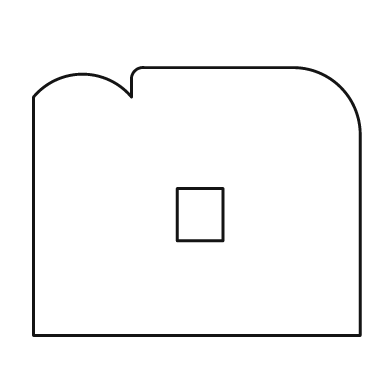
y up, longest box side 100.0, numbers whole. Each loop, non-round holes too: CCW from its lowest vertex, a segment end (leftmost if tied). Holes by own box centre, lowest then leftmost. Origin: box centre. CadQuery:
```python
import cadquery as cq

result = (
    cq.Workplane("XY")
    .moveTo(-50.0, -41.0)
    .lineTo(50.0, -41.0)
    .lineTo(50.0, 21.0)
    .threePointArc((44.0, 35.0), (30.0, 41.0))
    .lineTo(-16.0, 41.0)
    .threePointArc((-19.0, 40.0), (-20.0, 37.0))
    .lineTo(-20.0, 32.0)
    .threePointArc((-35.0, 39.0), (-50.0, 32.0))
    .close()
    .moveTo(-6.0, -12.0)
    .lineTo(8.0, -12.0)
    .lineTo(8.0, 4.0)
    .lineTo(-6.0, 4.0)
    .close()
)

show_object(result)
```